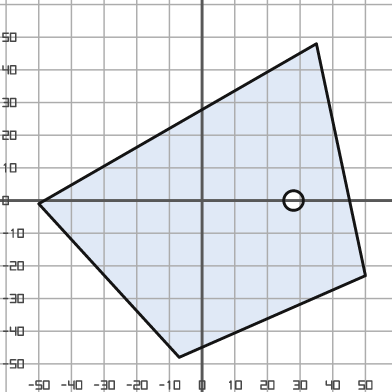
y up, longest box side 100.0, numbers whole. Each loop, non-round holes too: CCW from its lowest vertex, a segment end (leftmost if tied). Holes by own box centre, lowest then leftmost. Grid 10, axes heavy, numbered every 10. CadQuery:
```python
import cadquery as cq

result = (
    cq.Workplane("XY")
    .moveTo(-7.0, -48.0)
    .lineTo(50.0, -23.0)
    .lineTo(35.0, 48.0)
    .lineTo(-50.0, -1.0)
    .close()
    .moveTo(28.0, 0.0)
    .circle(3.0)
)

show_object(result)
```